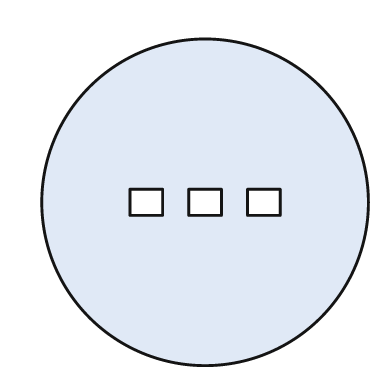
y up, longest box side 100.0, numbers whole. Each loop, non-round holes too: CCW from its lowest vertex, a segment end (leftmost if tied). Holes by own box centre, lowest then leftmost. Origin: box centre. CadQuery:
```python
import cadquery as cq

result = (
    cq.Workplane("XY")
    .moveTo(0.0, 0.0)
    .circle(50.0)
    .moveTo(-23.0, -4.0)
    .lineTo(-13.0, -4.0)
    .lineTo(-13.0, 4.0)
    .lineTo(-23.0, 4.0)
    .close()
    .moveTo(-5.0, -4.0)
    .lineTo(5.0, -4.0)
    .lineTo(5.0, 4.0)
    .lineTo(-5.0, 4.0)
    .close()
    .moveTo(13.0, -4.0)
    .lineTo(23.0, -4.0)
    .lineTo(23.0, 4.0)
    .lineTo(13.0, 4.0)
    .close()
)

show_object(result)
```